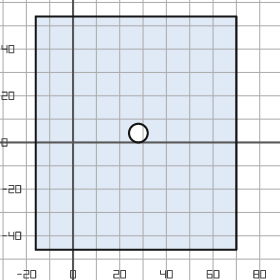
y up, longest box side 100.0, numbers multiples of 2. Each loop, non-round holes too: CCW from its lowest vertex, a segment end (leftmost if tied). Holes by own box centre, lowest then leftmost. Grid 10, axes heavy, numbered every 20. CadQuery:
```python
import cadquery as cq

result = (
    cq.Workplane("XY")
    .moveTo(-16.0, -46.0)
    .lineTo(70.0, -46.0)
    .lineTo(70.0, 54.0)
    .lineTo(-16.0, 54.0)
    .close()
    .moveTo(28.0, 4.0)
    .circle(4.0)
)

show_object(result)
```